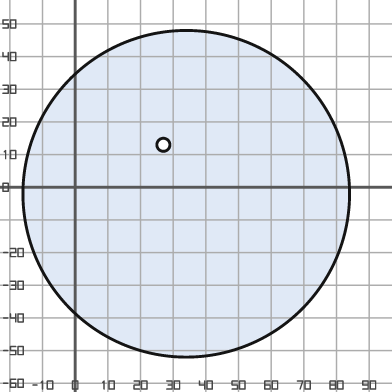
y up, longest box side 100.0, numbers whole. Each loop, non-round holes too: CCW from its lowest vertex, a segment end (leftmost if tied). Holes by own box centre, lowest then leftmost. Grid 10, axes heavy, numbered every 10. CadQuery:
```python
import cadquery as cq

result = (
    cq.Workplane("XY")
    .moveTo(34.0, -2.0)
    .circle(50.0)
    .moveTo(27.0, 13.0)
    .circle(2.0)
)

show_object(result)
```